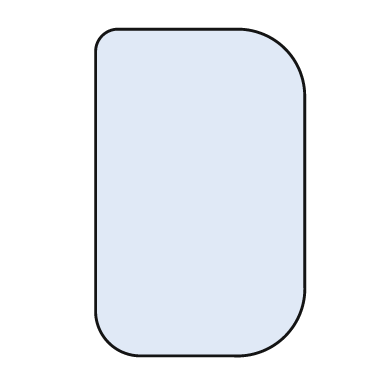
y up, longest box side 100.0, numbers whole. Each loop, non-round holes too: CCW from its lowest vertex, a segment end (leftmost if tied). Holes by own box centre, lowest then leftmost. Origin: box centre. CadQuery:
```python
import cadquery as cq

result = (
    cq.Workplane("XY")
    .moveTo(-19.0, -50.0)
    .lineTo(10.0, -50.0)
    .threePointArc((26.0, -44.0), (32.0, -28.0))
    .lineTo(32.0, 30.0)
    .threePointArc((26.0, 44.0), (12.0, 50.0))
    .lineTo(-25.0, 50.0)
    .threePointArc((-30.0, 48.0), (-32.0, 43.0))
    .lineTo(-32.0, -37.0)
    .threePointArc((-28.0, -46.0), (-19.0, -50.0))
    .close()
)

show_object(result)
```